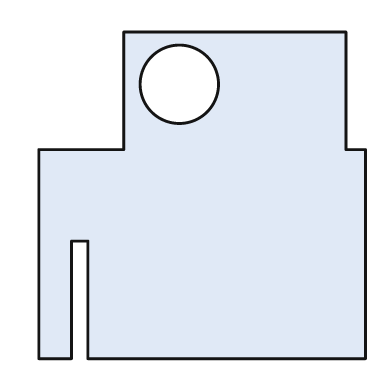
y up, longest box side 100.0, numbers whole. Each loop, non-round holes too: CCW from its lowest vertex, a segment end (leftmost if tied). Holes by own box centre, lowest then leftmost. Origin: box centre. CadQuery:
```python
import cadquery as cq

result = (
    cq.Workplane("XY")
    .moveTo(-50.0, -50.0)
    .lineTo(-40.0, -50.0)
    .lineTo(-40.0, -14.0)
    .lineTo(-35.0, -14.0)
    .lineTo(-35.0, -50.0)
    .lineTo(50.0, -50.0)
    .lineTo(50.0, 14.0)
    .lineTo(44.0, 14.0)
    .lineTo(44.0, 50.0)
    .lineTo(-24.0, 50.0)
    .lineTo(-24.0, 14.0)
    .lineTo(-50.0, 14.0)
    .close()
    .moveTo(-7.0, 34.0)
    .circle(12.0)
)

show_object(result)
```